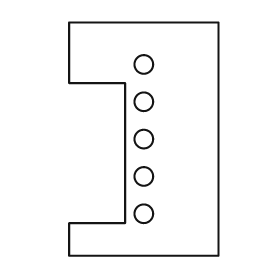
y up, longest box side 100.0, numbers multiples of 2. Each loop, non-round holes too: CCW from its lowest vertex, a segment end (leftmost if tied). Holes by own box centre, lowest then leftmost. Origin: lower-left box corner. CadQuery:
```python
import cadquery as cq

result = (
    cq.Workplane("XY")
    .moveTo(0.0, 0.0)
    .lineTo(64.0, 0.0)
    .lineTo(64.0, 100.0)
    .lineTo(0.0, 100.0)
    .lineTo(0.0, 74.0)
    .lineTo(24.0, 74.0)
    .lineTo(24.0, 14.0)
    .lineTo(0.0, 14.0)
    .close()
    .moveTo(32.0, 18.0)
    .circle(4.0)
    .moveTo(32.0, 34.0)
    .circle(4.0)
    .moveTo(32.0, 50.0)
    .circle(4.0)
    .moveTo(32.0, 66.0)
    .circle(4.0)
    .moveTo(32.0, 82.0)
    .circle(4.0)
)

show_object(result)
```